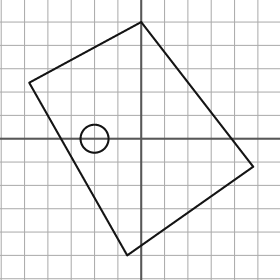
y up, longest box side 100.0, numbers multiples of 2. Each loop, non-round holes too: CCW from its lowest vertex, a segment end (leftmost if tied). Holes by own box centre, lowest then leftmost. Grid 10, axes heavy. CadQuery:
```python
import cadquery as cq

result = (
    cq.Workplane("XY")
    .moveTo(-6.0, -50.0)
    .lineTo(48.0, -12.0)
    .lineTo(0.0, 50.0)
    .lineTo(-48.0, 24.0)
    .close()
    .moveTo(-20.0, 0.0)
    .circle(6.0)
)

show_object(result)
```